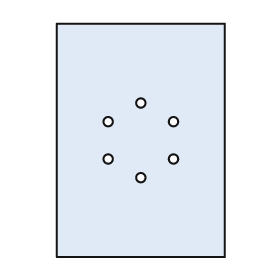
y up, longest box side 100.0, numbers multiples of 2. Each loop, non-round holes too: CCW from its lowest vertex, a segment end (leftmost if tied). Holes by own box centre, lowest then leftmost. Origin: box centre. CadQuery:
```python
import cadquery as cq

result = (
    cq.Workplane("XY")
    .moveTo(-36.0, -50.0)
    .lineTo(36.0, -50.0)
    .lineTo(36.0, 50.0)
    .lineTo(-36.0, 50.0)
    .close()
    .moveTo(0.0, -16.0)
    .circle(2.0)
    .moveTo(-14.0, -8.0)
    .circle(2.0)
    .moveTo(14.0, -8.0)
    .circle(2.0)
    .moveTo(-14.0, 8.0)
    .circle(2.0)
    .moveTo(14.0, 8.0)
    .circle(2.0)
    .moveTo(0.0, 16.0)
    .circle(2.0)
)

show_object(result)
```